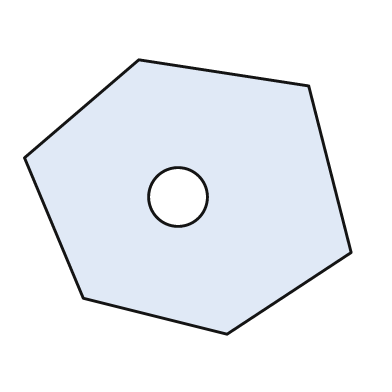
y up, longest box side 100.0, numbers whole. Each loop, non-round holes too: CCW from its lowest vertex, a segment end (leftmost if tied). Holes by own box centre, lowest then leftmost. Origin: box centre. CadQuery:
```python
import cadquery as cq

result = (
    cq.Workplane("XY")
    .moveTo(12.0, -42.0)
    .lineTo(50.0, -17.0)
    .lineTo(37.0, 34.0)
    .lineTo(-15.0, 42.0)
    .lineTo(-50.0, 12.0)
    .lineTo(-32.0, -31.0)
    .close()
    .moveTo(-3.0, 0.0)
    .circle(9.0)
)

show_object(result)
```